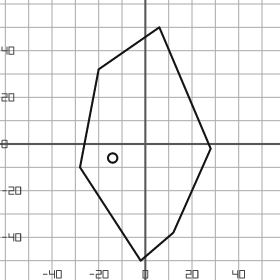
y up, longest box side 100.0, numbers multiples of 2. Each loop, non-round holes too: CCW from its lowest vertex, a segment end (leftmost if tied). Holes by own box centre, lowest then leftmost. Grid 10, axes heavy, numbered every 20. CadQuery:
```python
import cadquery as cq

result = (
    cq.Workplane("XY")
    .moveTo(-2.0, -50.0)
    .lineTo(12.0, -38.0)
    .lineTo(28.0, -2.0)
    .lineTo(6.0, 50.0)
    .lineTo(-20.0, 32.0)
    .lineTo(-28.0, -10.0)
    .close()
    .moveTo(-14.0, -6.0)
    .circle(2.0)
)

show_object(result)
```